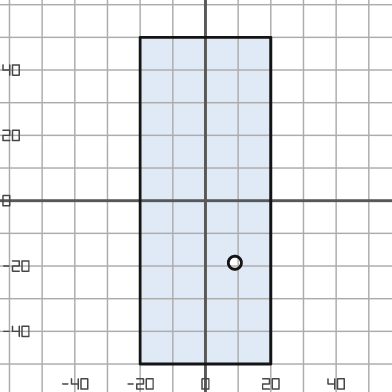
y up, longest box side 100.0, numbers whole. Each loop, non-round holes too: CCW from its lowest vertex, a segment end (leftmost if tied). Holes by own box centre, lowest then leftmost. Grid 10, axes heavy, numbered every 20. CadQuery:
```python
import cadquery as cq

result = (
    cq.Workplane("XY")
    .moveTo(-20.0, -50.0)
    .lineTo(20.0, -50.0)
    .lineTo(20.0, 50.0)
    .lineTo(-20.0, 50.0)
    .close()
    .moveTo(9.0, -19.0)
    .circle(2.0)
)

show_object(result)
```